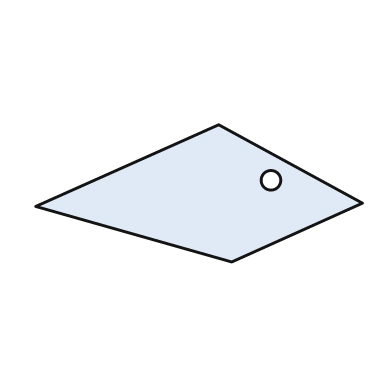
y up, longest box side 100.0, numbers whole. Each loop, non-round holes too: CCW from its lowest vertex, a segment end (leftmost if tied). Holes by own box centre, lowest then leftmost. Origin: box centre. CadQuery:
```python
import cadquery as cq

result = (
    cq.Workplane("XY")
    .moveTo(10.0, -21.0)
    .lineTo(50.0, -3.0)
    .lineTo(6.0, 21.0)
    .lineTo(-50.0, -4.0)
    .close()
    .moveTo(22.0, 4.0)
    .circle(3.0)
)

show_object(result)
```